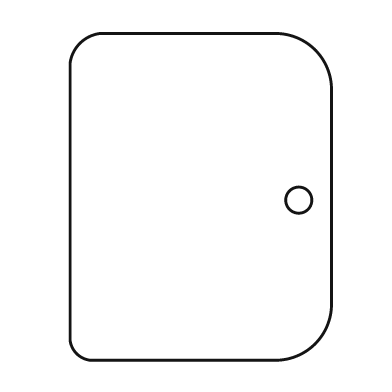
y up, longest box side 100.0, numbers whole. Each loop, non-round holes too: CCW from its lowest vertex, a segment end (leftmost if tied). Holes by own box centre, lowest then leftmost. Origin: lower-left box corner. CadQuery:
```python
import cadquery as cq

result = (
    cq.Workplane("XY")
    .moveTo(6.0, 0.0)
    .lineTo(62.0, 0.0)
    .threePointArc((75.0, 5.0), (80.0, 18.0))
    .lineTo(80.0, 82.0)
    .threePointArc((75.0, 95.0), (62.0, 100.0))
    .lineTo(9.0, 100.0)
    .threePointArc((3.0, 97.0), (0.0, 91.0))
    .lineTo(0.0, 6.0)
    .threePointArc((2.0, 2.0), (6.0, 0.0))
    .close()
    .moveTo(70.0, 49.0)
    .circle(4.0)
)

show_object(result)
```